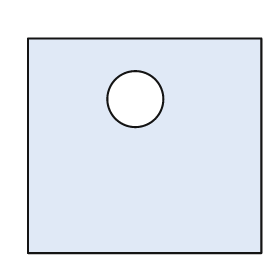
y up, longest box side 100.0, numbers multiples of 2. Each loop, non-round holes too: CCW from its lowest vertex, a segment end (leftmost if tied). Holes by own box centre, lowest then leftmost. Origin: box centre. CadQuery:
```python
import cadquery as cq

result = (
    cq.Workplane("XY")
    .moveTo(-50.0, -46.0)
    .lineTo(50.0, -46.0)
    .lineTo(50.0, 46.0)
    .lineTo(-50.0, 46.0)
    .close()
    .moveTo(-4.0, 20.0)
    .circle(12.0)
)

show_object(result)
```